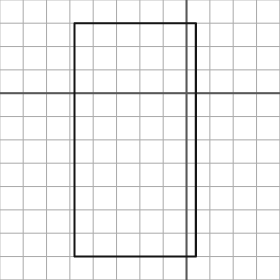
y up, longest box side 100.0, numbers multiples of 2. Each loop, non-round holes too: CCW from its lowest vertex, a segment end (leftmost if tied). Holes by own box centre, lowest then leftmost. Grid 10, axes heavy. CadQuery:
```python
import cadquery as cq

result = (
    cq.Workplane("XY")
    .moveTo(-48.0, -70.0)
    .lineTo(4.0, -70.0)
    .lineTo(4.0, 30.0)
    .lineTo(-48.0, 30.0)
    .close()
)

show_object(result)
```